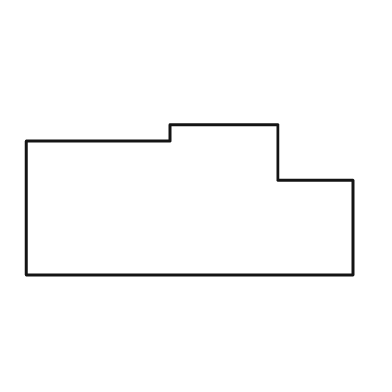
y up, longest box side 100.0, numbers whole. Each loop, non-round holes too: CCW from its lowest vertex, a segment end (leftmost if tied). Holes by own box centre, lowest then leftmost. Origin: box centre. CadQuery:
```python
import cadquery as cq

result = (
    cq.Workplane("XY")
    .moveTo(-50.0, -23.0)
    .lineTo(50.0, -23.0)
    .lineTo(50.0, 6.0)
    .lineTo(27.0, 6.0)
    .lineTo(27.0, 23.0)
    .lineTo(-6.0, 23.0)
    .lineTo(-6.0, 18.0)
    .lineTo(-50.0, 18.0)
    .close()
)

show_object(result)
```